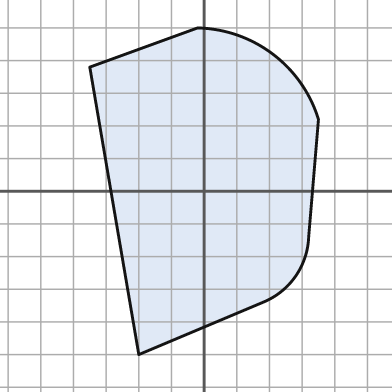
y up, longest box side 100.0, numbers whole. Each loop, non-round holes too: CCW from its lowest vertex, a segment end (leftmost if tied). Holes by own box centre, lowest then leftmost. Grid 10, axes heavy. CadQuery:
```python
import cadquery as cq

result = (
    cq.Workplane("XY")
    .moveTo(-20.0, -50.0)
    .lineTo(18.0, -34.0)
    .threePointArc((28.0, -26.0), (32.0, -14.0))
    .lineTo(35.0, 22.0)
    .threePointArc((21.0, 42.0), (-2.0, 50.0))
    .lineTo(-35.0, 38.0)
    .close()
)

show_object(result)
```